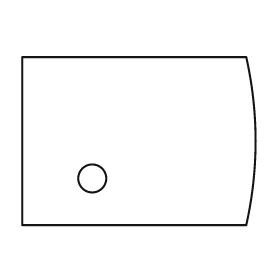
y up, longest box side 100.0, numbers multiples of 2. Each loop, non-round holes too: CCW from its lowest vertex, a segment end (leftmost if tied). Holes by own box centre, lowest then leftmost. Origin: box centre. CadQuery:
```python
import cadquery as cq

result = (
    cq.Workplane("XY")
    .moveTo(-50.0, -36.0)
    .lineTo(46.0, -36.0)
    .threePointArc((50.0, 0.0), (46.0, 36.0))
    .lineTo(-50.0, 36.0)
    .close()
    .moveTo(-20.0, -16.0)
    .circle(6.0)
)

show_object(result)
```